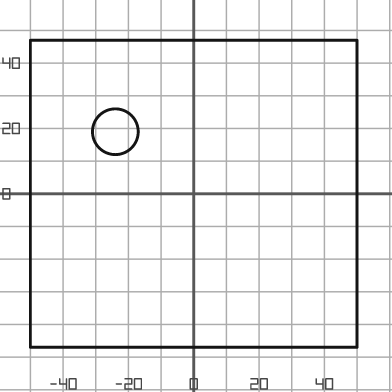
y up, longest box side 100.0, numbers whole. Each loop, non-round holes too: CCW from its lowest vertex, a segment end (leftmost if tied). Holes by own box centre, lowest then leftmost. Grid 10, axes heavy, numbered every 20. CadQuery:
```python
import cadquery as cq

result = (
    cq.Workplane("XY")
    .moveTo(-50.0, -47.0)
    .lineTo(50.0, -47.0)
    .lineTo(50.0, 47.0)
    .lineTo(-50.0, 47.0)
    .close()
    .moveTo(-24.0, 19.0)
    .circle(7.0)
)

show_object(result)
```